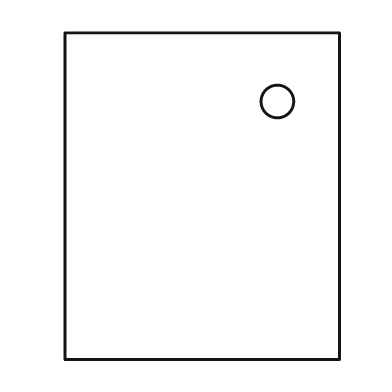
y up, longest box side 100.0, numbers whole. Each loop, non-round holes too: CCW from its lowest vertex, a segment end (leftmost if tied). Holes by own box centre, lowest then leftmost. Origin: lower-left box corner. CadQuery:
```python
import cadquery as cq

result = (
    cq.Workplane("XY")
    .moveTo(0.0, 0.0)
    .lineTo(84.0, 0.0)
    .lineTo(84.0, 100.0)
    .lineTo(0.0, 100.0)
    .close()
    .moveTo(65.0, 79.0)
    .circle(5.0)
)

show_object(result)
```